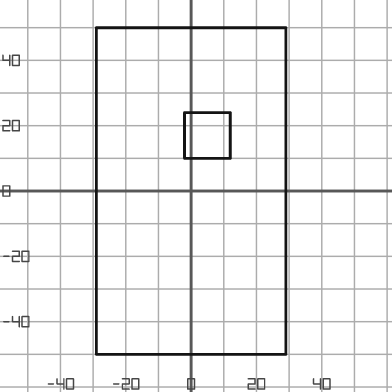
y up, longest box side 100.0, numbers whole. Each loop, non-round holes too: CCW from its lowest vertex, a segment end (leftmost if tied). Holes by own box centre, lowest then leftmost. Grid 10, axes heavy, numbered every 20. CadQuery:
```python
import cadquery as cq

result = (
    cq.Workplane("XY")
    .moveTo(-29.0, -50.0)
    .lineTo(29.0, -50.0)
    .lineTo(29.0, 50.0)
    .lineTo(-29.0, 50.0)
    .close()
    .moveTo(-2.0, 10.0)
    .lineTo(12.0, 10.0)
    .lineTo(12.0, 24.0)
    .lineTo(-2.0, 24.0)
    .close()
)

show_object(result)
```